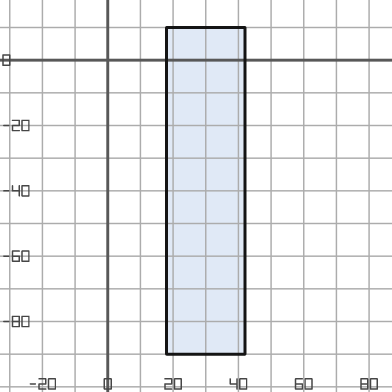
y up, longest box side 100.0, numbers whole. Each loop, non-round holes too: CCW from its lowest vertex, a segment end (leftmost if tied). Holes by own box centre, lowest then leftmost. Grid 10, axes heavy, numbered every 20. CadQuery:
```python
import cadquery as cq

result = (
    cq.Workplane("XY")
    .moveTo(18.0, -90.0)
    .lineTo(42.0, -90.0)
    .lineTo(42.0, 10.0)
    .lineTo(18.0, 10.0)
    .close()
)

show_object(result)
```